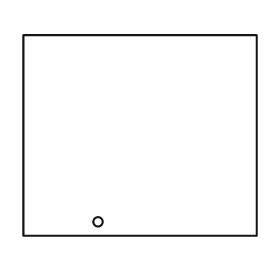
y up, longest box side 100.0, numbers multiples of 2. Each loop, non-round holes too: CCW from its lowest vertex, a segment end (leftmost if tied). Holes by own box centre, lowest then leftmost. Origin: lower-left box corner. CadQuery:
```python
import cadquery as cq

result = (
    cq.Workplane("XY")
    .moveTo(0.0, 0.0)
    .lineTo(100.0, 0.0)
    .lineTo(100.0, 86.0)
    .lineTo(0.0, 86.0)
    .close()
    .moveTo(32.0, 6.0)
    .circle(2.0)
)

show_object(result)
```